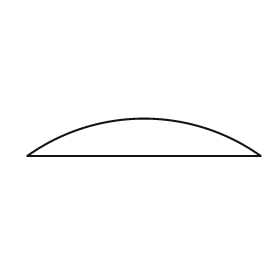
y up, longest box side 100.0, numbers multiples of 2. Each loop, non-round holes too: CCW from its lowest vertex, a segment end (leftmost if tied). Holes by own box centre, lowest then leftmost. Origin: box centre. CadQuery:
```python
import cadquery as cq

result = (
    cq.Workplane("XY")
    .moveTo(-50.0, -8.0)
    .lineTo(50.0, -8.0)
    .threePointArc((0.0, 8.0), (-50.0, -8.0))
    .close()
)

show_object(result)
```